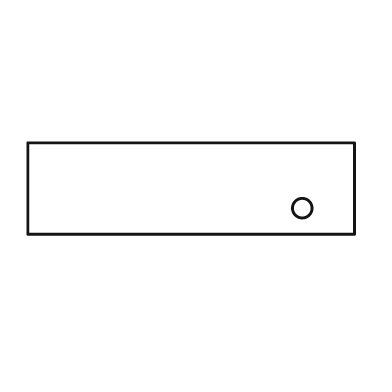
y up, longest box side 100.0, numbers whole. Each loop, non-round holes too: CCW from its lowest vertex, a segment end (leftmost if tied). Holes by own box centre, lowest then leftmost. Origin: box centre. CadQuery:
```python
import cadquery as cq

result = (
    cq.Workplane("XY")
    .moveTo(-50.0, -14.0)
    .lineTo(50.0, -14.0)
    .lineTo(50.0, 14.0)
    .lineTo(-50.0, 14.0)
    .close()
    .moveTo(34.0, -6.0)
    .circle(3.0)
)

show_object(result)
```